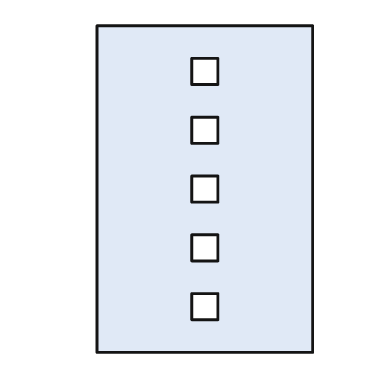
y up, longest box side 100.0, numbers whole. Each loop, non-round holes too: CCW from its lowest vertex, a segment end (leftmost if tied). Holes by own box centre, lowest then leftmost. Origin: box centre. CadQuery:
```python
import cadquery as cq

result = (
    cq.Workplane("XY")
    .moveTo(-33.0, -50.0)
    .lineTo(33.0, -50.0)
    .lineTo(33.0, 50.0)
    .lineTo(-33.0, 50.0)
    .close()
    .moveTo(-4.0, -40.0)
    .lineTo(4.0, -40.0)
    .lineTo(4.0, -32.0)
    .lineTo(-4.0, -32.0)
    .close()
    .moveTo(-4.0, -22.0)
    .lineTo(4.0, -22.0)
    .lineTo(4.0, -14.0)
    .lineTo(-4.0, -14.0)
    .close()
    .moveTo(-4.0, -4.0)
    .lineTo(4.0, -4.0)
    .lineTo(4.0, 4.0)
    .lineTo(-4.0, 4.0)
    .close()
    .moveTo(-4.0, 14.0)
    .lineTo(4.0, 14.0)
    .lineTo(4.0, 22.0)
    .lineTo(-4.0, 22.0)
    .close()
    .moveTo(-4.0, 32.0)
    .lineTo(4.0, 32.0)
    .lineTo(4.0, 40.0)
    .lineTo(-4.0, 40.0)
    .close()
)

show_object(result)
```